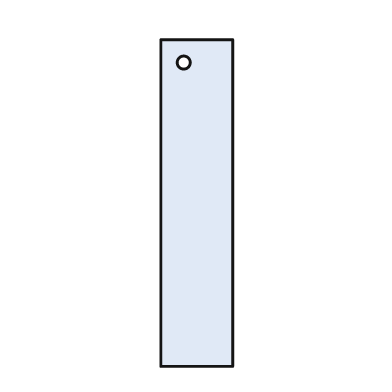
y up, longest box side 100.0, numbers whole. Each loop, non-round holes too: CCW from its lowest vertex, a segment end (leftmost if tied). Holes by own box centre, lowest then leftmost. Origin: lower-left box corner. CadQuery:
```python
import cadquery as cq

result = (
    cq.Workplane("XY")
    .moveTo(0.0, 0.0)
    .lineTo(22.0, 0.0)
    .lineTo(22.0, 100.0)
    .lineTo(0.0, 100.0)
    .close()
    .moveTo(7.0, 93.0)
    .circle(2.0)
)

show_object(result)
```